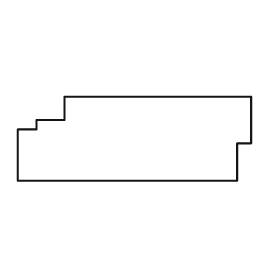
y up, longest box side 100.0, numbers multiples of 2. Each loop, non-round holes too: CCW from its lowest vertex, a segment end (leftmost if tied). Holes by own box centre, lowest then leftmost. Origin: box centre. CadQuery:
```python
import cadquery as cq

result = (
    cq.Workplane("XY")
    .moveTo(-50.0, -18.0)
    .lineTo(44.0, -18.0)
    .lineTo(44.0, -2.0)
    .lineTo(50.0, -2.0)
    .lineTo(50.0, 18.0)
    .lineTo(-30.0, 18.0)
    .lineTo(-30.0, 8.0)
    .lineTo(-42.0, 8.0)
    .lineTo(-42.0, 4.0)
    .lineTo(-50.0, 4.0)
    .close()
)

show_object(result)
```